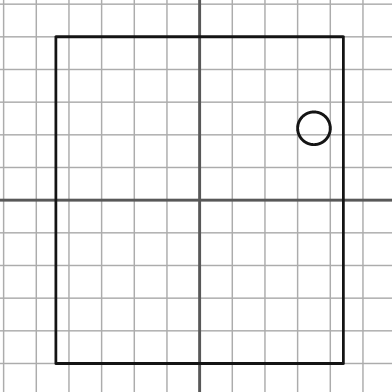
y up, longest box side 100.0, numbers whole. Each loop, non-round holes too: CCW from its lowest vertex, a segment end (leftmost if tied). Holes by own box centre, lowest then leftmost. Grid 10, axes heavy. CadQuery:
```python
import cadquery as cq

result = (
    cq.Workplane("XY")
    .moveTo(-44.0, -50.0)
    .lineTo(44.0, -50.0)
    .lineTo(44.0, 50.0)
    .lineTo(-44.0, 50.0)
    .close()
    .moveTo(35.0, 22.0)
    .circle(5.0)
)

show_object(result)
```